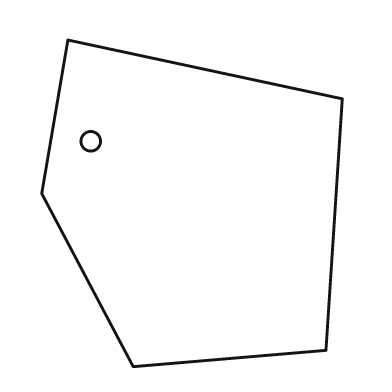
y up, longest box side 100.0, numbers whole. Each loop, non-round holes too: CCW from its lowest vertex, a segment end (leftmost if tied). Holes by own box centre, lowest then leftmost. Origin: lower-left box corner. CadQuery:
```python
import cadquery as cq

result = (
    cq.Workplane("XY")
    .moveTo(28.0, 0.0)
    .lineTo(87.0, 5.0)
    .lineTo(92.0, 82.0)
    .lineTo(8.0, 100.0)
    .lineTo(0.0, 53.0)
    .close()
    .moveTo(15.0, 69.0)
    .circle(3.0)
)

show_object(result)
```